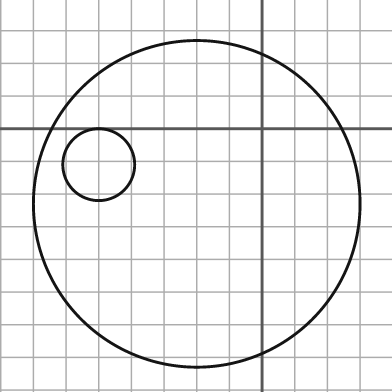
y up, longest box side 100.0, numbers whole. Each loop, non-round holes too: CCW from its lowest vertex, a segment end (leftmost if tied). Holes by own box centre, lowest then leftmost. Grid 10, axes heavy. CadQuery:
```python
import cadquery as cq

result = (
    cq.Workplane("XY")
    .moveTo(-20.0, -23.0)
    .circle(50.0)
    .moveTo(-50.0, -11.0)
    .circle(11.0)
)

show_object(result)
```